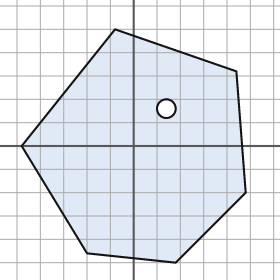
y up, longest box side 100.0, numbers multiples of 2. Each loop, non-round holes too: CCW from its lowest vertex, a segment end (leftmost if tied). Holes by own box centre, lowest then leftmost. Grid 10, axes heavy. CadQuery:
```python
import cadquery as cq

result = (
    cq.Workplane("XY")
    .moveTo(18.0, -50.0)
    .lineTo(48.0, -20.0)
    .lineTo(44.0, 32.0)
    .lineTo(-8.0, 50.0)
    .lineTo(-48.0, 0.0)
    .lineTo(-20.0, -46.0)
    .close()
    .moveTo(14.0, 16.0)
    .circle(4.0)
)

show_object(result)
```